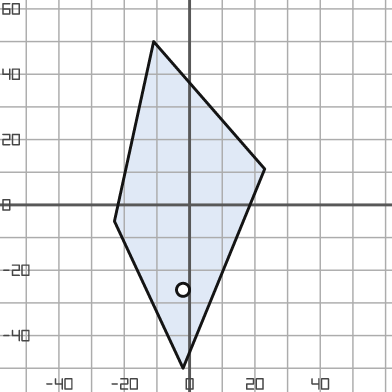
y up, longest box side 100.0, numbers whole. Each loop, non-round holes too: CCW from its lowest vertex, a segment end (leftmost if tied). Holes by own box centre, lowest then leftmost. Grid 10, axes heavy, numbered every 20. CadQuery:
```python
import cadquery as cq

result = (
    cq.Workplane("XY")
    .moveTo(-2.0, -50.0)
    .lineTo(23.0, 11.0)
    .lineTo(-11.0, 50.0)
    .lineTo(-23.0, -5.0)
    .close()
    .moveTo(-2.0, -26.0)
    .circle(2.0)
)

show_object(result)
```